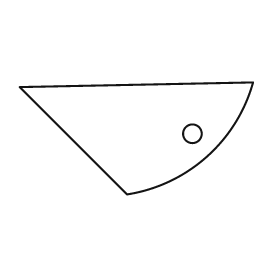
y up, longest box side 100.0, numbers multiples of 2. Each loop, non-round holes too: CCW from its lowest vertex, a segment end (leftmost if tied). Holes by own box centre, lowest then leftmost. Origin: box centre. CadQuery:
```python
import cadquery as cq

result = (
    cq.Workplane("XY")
    .moveTo(-4.0, -24.0)
    .threePointArc((30.0, -8.0), (50.0, 24.0))
    .lineTo(-50.0, 22.0)
    .close()
    .moveTo(24.0, 2.0)
    .circle(4.0)
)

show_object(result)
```